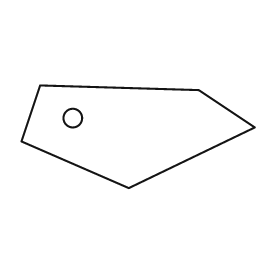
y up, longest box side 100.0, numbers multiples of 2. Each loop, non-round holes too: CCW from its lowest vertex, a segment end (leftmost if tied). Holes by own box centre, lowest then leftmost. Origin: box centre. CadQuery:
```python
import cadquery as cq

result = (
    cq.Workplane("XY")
    .moveTo(-4.0, -22.0)
    .lineTo(50.0, 4.0)
    .lineTo(26.0, 20.0)
    .lineTo(-42.0, 22.0)
    .lineTo(-50.0, -2.0)
    .close()
    .moveTo(-28.0, 8.0)
    .circle(4.0)
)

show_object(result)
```